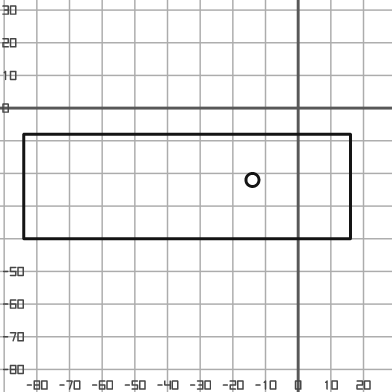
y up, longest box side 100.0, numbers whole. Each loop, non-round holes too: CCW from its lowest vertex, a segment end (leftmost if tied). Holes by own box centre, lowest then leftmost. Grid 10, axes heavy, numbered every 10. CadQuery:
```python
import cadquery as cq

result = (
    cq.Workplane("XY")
    .moveTo(-84.0, -40.0)
    .lineTo(16.0, -40.0)
    .lineTo(16.0, -8.0)
    .lineTo(-84.0, -8.0)
    .close()
    .moveTo(-14.0, -22.0)
    .circle(2.0)
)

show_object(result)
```